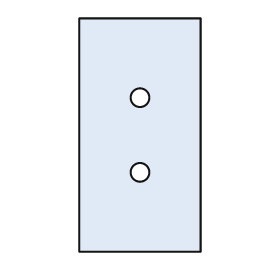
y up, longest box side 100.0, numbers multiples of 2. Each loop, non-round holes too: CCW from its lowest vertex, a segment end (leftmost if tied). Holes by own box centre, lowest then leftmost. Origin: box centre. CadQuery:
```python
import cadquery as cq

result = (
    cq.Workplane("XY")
    .moveTo(-26.0, -50.0)
    .lineTo(26.0, -50.0)
    .lineTo(26.0, 50.0)
    .lineTo(-26.0, 50.0)
    .close()
    .moveTo(0.0, -16.0)
    .circle(4.0)
    .moveTo(0.0, 16.0)
    .circle(4.0)
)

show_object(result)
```